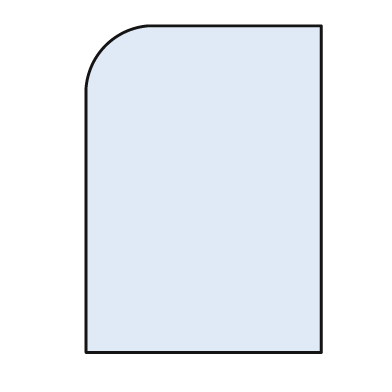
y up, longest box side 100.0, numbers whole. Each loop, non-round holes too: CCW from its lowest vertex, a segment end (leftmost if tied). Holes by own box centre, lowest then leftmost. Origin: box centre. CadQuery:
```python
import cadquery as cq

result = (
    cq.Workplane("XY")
    .moveTo(-36.0, -50.0)
    .lineTo(36.0, -50.0)
    .lineTo(36.0, 50.0)
    .lineTo(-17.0, 50.0)
    .threePointArc((-30.0, 44.0), (-36.0, 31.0))
    .close()
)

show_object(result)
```